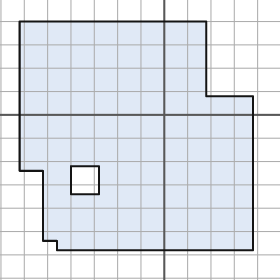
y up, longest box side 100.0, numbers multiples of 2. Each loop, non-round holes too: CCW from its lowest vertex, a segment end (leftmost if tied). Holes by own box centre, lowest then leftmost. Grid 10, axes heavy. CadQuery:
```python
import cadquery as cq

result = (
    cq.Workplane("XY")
    .moveTo(-46.0, -58.0)
    .lineTo(38.0, -58.0)
    .lineTo(38.0, 8.0)
    .lineTo(18.0, 8.0)
    .lineTo(18.0, 40.0)
    .lineTo(-62.0, 40.0)
    .lineTo(-62.0, -24.0)
    .lineTo(-52.0, -24.0)
    .lineTo(-52.0, -54.0)
    .lineTo(-46.0, -54.0)
    .close()
    .moveTo(-40.0, -34.0)
    .lineTo(-28.0, -34.0)
    .lineTo(-28.0, -22.0)
    .lineTo(-40.0, -22.0)
    .close()
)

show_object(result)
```